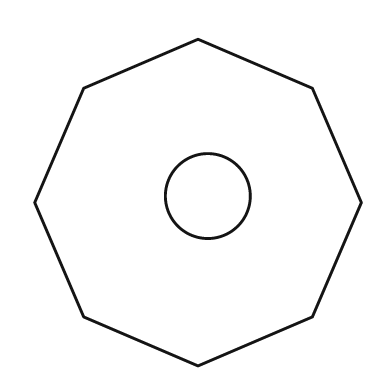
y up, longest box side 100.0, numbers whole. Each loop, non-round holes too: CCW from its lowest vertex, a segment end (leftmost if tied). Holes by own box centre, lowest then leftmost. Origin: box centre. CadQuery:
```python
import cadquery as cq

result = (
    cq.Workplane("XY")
    .moveTo(0.0, -50.0)
    .lineTo(35.0, -35.0)
    .lineTo(50.0, 0.0)
    .lineTo(35.0, 35.0)
    .lineTo(0.0, 50.0)
    .lineTo(-35.0, 35.0)
    .lineTo(-50.0, 0.0)
    .lineTo(-35.0, -35.0)
    .close()
    .moveTo(3.0, 2.0)
    .circle(13.0)
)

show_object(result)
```